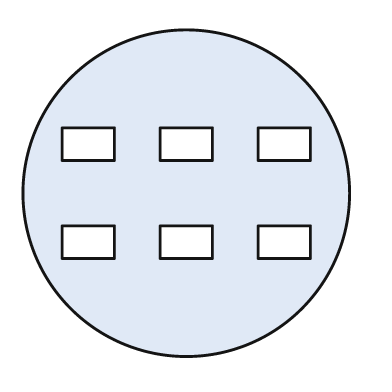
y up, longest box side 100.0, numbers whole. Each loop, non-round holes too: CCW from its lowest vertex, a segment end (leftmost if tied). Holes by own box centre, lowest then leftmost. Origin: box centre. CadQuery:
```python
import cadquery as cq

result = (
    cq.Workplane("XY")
    .moveTo(0.0, 0.0)
    .circle(50.0)
    .moveTo(-38.0, -20.0)
    .lineTo(-22.0, -20.0)
    .lineTo(-22.0, -10.0)
    .lineTo(-38.0, -10.0)
    .close()
    .moveTo(-8.0, -20.0)
    .lineTo(8.0, -20.0)
    .lineTo(8.0, -10.0)
    .lineTo(-8.0, -10.0)
    .close()
    .moveTo(22.0, -20.0)
    .lineTo(38.0, -20.0)
    .lineTo(38.0, -10.0)
    .lineTo(22.0, -10.0)
    .close()
    .moveTo(-38.0, 10.0)
    .lineTo(-22.0, 10.0)
    .lineTo(-22.0, 20.0)
    .lineTo(-38.0, 20.0)
    .close()
    .moveTo(-8.0, 10.0)
    .lineTo(8.0, 10.0)
    .lineTo(8.0, 20.0)
    .lineTo(-8.0, 20.0)
    .close()
    .moveTo(22.0, 10.0)
    .lineTo(38.0, 10.0)
    .lineTo(38.0, 20.0)
    .lineTo(22.0, 20.0)
    .close()
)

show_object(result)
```